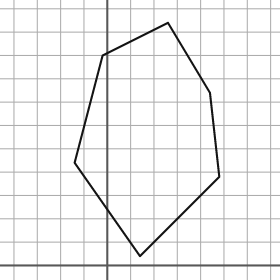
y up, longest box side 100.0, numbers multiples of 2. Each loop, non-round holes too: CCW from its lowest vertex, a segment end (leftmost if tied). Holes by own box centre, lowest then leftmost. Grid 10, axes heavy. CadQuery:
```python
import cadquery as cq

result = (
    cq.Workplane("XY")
    .moveTo(14.0, 4.0)
    .lineTo(48.0, 38.0)
    .lineTo(44.0, 74.0)
    .lineTo(26.0, 104.0)
    .lineTo(-2.0, 90.0)
    .lineTo(-14.0, 44.0)
    .close()
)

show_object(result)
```